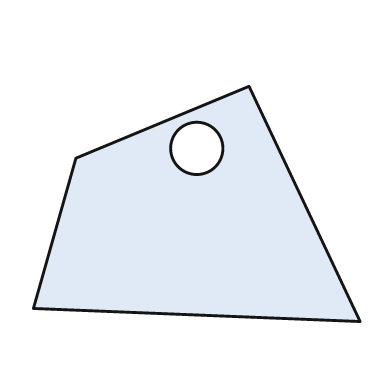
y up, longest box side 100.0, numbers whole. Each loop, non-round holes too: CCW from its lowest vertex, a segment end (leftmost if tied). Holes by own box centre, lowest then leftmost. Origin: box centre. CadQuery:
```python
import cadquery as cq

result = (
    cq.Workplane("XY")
    .moveTo(50.0, -36.0)
    .lineTo(16.0, 36.0)
    .lineTo(-37.0, 14.0)
    .lineTo(-50.0, -32.0)
    .close()
    .moveTo(0.0, 17.0)
    .circle(8.0)
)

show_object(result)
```